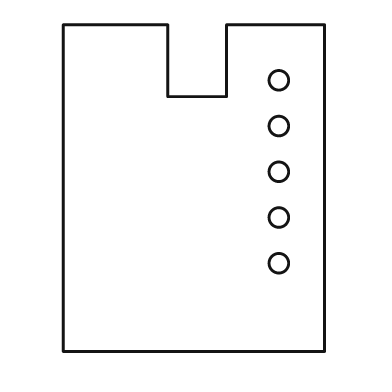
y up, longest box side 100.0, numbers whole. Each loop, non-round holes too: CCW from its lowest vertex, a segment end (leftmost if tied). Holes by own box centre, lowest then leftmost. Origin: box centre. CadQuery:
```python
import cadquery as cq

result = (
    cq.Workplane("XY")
    .moveTo(-40.0, -50.0)
    .lineTo(40.0, -50.0)
    .lineTo(40.0, 50.0)
    .lineTo(10.0, 50.0)
    .lineTo(10.0, 28.0)
    .lineTo(-8.0, 28.0)
    .lineTo(-8.0, 50.0)
    .lineTo(-40.0, 50.0)
    .close()
    .moveTo(26.0, -23.0)
    .circle(3.0)
    .moveTo(26.0, -9.0)
    .circle(3.0)
    .moveTo(26.0, 5.0)
    .circle(3.0)
    .moveTo(26.0, 19.0)
    .circle(3.0)
    .moveTo(26.0, 33.0)
    .circle(3.0)
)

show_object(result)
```